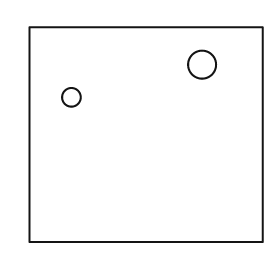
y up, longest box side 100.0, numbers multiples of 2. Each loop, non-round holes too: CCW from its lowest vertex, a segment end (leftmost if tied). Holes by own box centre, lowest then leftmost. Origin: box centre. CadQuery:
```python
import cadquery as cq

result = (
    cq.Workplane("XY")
    .moveTo(-50.0, -46.0)
    .lineTo(50.0, -46.0)
    .lineTo(50.0, 46.0)
    .lineTo(-50.0, 46.0)
    .close()
    .moveTo(-32.0, 16.0)
    .circle(4.0)
    .moveTo(24.0, 30.0)
    .circle(6.0)
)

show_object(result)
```